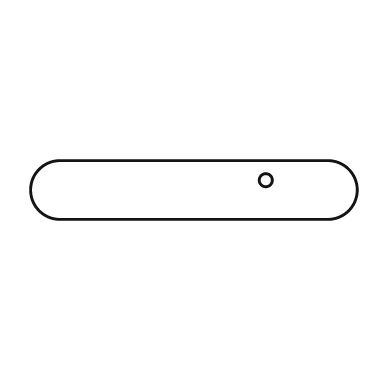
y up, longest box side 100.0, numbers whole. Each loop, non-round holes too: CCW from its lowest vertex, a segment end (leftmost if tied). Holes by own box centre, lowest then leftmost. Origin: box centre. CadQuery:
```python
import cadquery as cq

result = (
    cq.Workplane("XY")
    .moveTo(-41.0, -9.0)
    .lineTo(41.0, -9.0)
    .threePointArc((50.0, 0.0), (41.0, 9.0))
    .lineTo(-41.0, 9.0)
    .threePointArc((-50.0, 0.0), (-41.0, -9.0))
    .close()
    .moveTo(22.0, 3.0)
    .circle(2.0)
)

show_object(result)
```